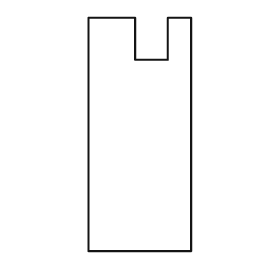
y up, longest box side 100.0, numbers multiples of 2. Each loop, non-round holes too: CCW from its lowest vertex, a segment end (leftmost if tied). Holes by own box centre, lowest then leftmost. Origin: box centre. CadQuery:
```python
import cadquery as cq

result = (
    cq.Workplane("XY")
    .moveTo(-22.0, -50.0)
    .lineTo(22.0, -50.0)
    .lineTo(22.0, 50.0)
    .lineTo(12.0, 50.0)
    .lineTo(12.0, 32.0)
    .lineTo(-2.0, 32.0)
    .lineTo(-2.0, 50.0)
    .lineTo(-22.0, 50.0)
    .close()
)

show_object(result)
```